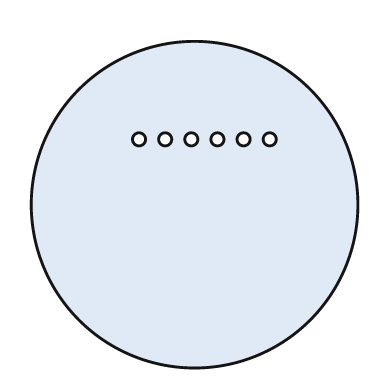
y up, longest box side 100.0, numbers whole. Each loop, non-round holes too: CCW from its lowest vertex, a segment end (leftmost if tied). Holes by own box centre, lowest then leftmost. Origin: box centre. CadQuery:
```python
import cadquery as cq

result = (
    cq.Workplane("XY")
    .moveTo(0.0, 0.0)
    .circle(50.0)
    .moveTo(-17.0, 20.0)
    .circle(2.0)
    .moveTo(-9.0, 20.0)
    .circle(2.0)
    .moveTo(-1.0, 20.0)
    .circle(2.0)
    .moveTo(7.0, 20.0)
    .circle(2.0)
    .moveTo(15.0, 20.0)
    .circle(2.0)
    .moveTo(23.0, 20.0)
    .circle(2.0)
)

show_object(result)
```